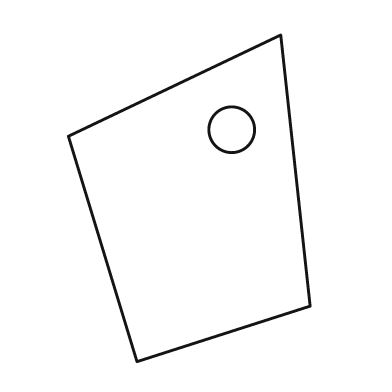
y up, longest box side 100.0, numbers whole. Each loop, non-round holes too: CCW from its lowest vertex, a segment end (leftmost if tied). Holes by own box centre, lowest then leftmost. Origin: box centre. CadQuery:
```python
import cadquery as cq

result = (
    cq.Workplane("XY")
    .moveTo(-16.0, -50.0)
    .lineTo(37.0, -33.0)
    .lineTo(28.0, 50.0)
    .lineTo(-37.0, 19.0)
    .close()
    .moveTo(13.0, 21.0)
    .circle(7.0)
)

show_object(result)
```